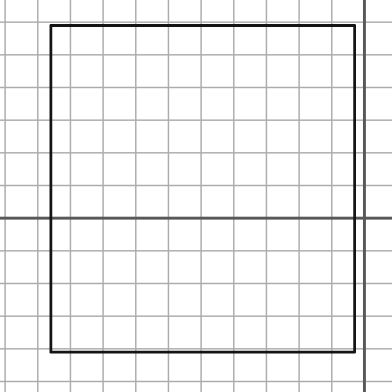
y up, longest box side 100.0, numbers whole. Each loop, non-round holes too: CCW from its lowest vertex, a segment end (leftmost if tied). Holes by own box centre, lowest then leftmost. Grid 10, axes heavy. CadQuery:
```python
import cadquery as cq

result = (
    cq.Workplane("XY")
    .moveTo(-96.0, -41.0)
    .lineTo(-3.0, -41.0)
    .lineTo(-3.0, 59.0)
    .lineTo(-96.0, 59.0)
    .close()
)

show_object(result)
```